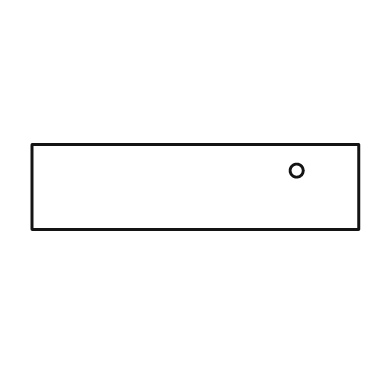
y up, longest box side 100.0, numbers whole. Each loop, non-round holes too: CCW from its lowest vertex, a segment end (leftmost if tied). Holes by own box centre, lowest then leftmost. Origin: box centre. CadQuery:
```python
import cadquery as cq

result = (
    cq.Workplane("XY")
    .moveTo(-50.0, -13.0)
    .lineTo(50.0, -13.0)
    .lineTo(50.0, 13.0)
    .lineTo(-50.0, 13.0)
    .close()
    .moveTo(31.0, 5.0)
    .circle(2.0)
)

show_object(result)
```